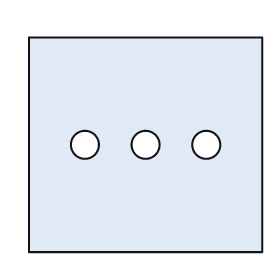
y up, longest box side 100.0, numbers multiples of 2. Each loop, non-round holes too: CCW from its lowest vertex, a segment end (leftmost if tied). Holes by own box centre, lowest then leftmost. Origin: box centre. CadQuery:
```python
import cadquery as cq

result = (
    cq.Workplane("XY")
    .moveTo(-50.0, -46.0)
    .lineTo(50.0, -46.0)
    .lineTo(50.0, 46.0)
    .lineTo(-50.0, 46.0)
    .close()
    .moveTo(-26.0, 0.0)
    .circle(6.0)
    .moveTo(0.0, 0.0)
    .circle(6.0)
    .moveTo(26.0, 0.0)
    .circle(6.0)
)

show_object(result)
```